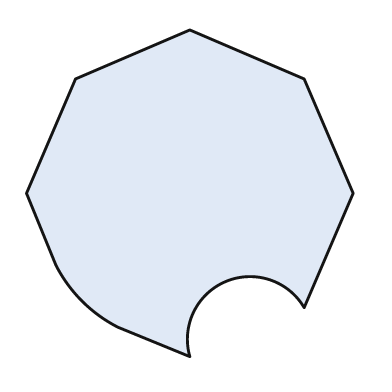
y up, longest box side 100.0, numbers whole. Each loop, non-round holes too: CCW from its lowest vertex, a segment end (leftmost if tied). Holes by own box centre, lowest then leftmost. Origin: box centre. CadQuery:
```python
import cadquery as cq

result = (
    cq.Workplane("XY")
    .moveTo(0.0, -50.0)
    .threePointArc((11.0, -27.0), (35.0, -35.0))
    .lineTo(50.0, 0.0)
    .lineTo(35.0, 35.0)
    .lineTo(0.0, 50.0)
    .lineTo(-35.0, 35.0)
    .lineTo(-50.0, 0.0)
    .lineTo(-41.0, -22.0)
    .threePointArc((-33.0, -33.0), (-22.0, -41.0))
    .close()
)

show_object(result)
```